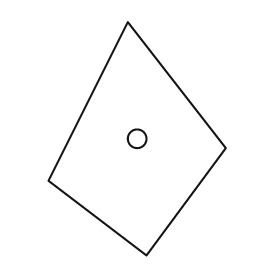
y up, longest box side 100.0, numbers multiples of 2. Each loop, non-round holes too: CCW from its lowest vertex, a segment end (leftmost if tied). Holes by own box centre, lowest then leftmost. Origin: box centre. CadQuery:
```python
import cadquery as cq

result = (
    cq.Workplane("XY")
    .moveTo(4.0, -50.0)
    .lineTo(38.0, -4.0)
    .lineTo(-4.0, 50.0)
    .lineTo(-38.0, -18.0)
    .close()
    .moveTo(0.0, 0.0)
    .circle(4.0)
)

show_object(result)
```